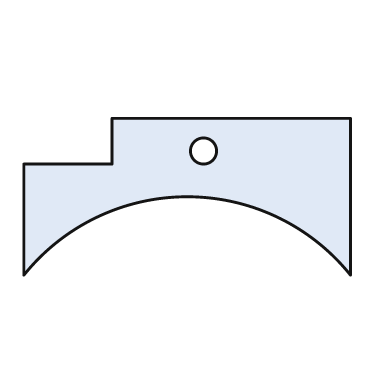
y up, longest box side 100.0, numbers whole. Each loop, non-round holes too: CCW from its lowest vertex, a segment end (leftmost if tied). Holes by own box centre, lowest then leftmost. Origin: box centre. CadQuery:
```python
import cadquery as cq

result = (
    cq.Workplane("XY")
    .moveTo(-50.0, -24.0)
    .threePointArc((0.0, 0.0), (50.0, -24.0))
    .lineTo(50.0, 24.0)
    .lineTo(-23.0, 24.0)
    .lineTo(-23.0, 10.0)
    .lineTo(-50.0, 10.0)
    .close()
    .moveTo(5.0, 14.0)
    .circle(4.0)
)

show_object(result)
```